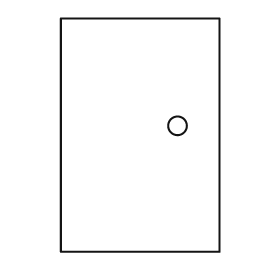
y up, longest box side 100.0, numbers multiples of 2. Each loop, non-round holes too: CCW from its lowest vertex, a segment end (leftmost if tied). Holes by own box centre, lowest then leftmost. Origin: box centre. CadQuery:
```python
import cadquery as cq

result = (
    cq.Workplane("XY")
    .moveTo(-34.0, -50.0)
    .lineTo(34.0, -50.0)
    .lineTo(34.0, 50.0)
    .lineTo(-34.0, 50.0)
    .close()
    .moveTo(16.0, 4.0)
    .circle(4.0)
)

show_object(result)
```